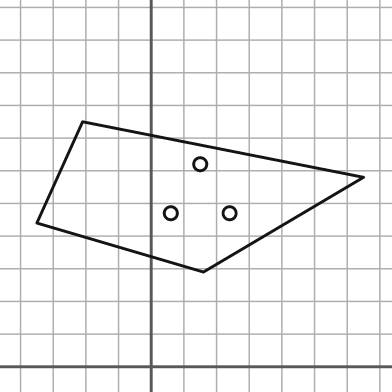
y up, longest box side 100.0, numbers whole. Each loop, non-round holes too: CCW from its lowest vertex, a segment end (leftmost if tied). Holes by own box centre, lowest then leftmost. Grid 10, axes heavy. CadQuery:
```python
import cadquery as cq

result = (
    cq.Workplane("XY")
    .moveTo(16.0, 29.0)
    .lineTo(65.0, 58.0)
    .lineTo(-21.0, 75.0)
    .lineTo(-35.0, 44.0)
    .close()
    .moveTo(6.0, 47.0)
    .circle(2.0)
    .moveTo(24.0, 47.0)
    .circle(2.0)
    .moveTo(15.0, 62.0)
    .circle(2.0)
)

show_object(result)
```